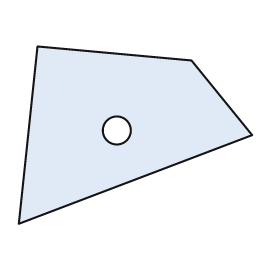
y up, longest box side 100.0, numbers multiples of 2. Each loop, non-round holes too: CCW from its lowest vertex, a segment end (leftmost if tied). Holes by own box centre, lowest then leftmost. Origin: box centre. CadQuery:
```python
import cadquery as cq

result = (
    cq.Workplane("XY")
    .moveTo(-50.0, -38.0)
    .lineTo(50.0, 0.0)
    .lineTo(24.0, 32.0)
    .lineTo(-42.0, 38.0)
    .close()
    .moveTo(-8.0, 2.0)
    .circle(6.0)
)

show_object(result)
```